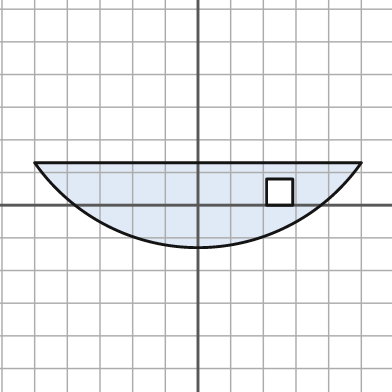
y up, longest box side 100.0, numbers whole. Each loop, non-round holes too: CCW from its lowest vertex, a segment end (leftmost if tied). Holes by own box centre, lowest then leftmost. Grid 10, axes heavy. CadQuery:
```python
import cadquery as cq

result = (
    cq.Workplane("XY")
    .moveTo(-50.0, 13.0)
    .threePointArc((0.0, -13.0), (50.0, 13.0))
    .close()
    .moveTo(21.0, 0.0)
    .lineTo(29.0, 0.0)
    .lineTo(29.0, 8.0)
    .lineTo(21.0, 8.0)
    .close()
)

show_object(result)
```